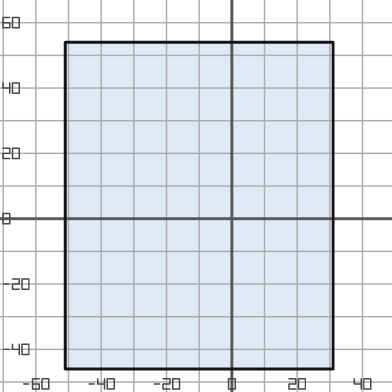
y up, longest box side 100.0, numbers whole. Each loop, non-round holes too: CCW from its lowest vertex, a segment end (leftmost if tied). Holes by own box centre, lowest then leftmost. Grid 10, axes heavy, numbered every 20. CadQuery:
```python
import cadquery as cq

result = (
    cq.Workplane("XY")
    .moveTo(-51.0, -46.0)
    .lineTo(31.0, -46.0)
    .lineTo(31.0, 54.0)
    .lineTo(-51.0, 54.0)
    .close()
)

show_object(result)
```